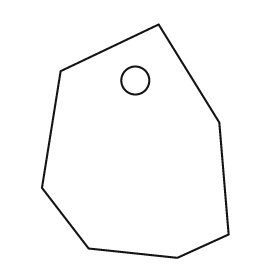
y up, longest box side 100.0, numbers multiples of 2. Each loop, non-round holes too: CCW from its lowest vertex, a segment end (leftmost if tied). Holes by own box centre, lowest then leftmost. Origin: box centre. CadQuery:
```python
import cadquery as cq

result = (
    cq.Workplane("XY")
    .moveTo(18.0, -50.0)
    .lineTo(40.0, -40.0)
    .lineTo(36.0, 8.0)
    .lineTo(10.0, 50.0)
    .lineTo(-32.0, 30.0)
    .lineTo(-40.0, -20.0)
    .lineTo(-20.0, -46.0)
    .close()
    .moveTo(0.0, 26.0)
    .circle(6.0)
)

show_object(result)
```